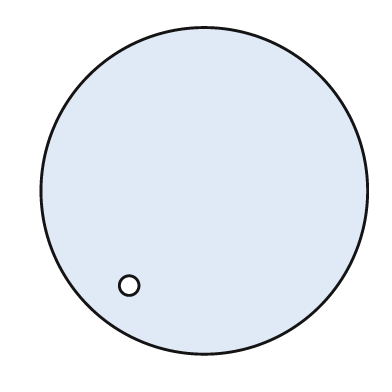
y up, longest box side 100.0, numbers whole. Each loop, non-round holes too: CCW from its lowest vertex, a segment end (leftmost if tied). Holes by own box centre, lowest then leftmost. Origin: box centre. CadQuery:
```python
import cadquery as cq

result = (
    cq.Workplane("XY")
    .moveTo(0.0, 0.0)
    .circle(50.0)
    .moveTo(-23.0, -29.0)
    .circle(3.0)
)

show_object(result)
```